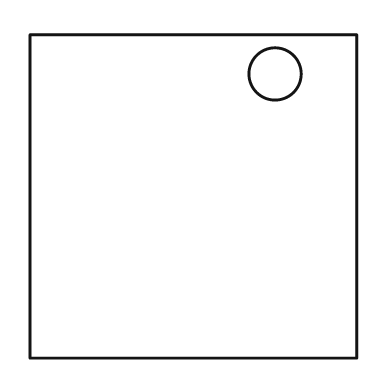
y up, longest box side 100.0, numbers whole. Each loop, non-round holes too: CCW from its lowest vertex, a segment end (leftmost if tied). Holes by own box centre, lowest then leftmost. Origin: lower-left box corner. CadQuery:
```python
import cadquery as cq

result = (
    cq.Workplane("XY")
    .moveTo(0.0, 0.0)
    .lineTo(100.0, 0.0)
    .lineTo(100.0, 99.0)
    .lineTo(0.0, 99.0)
    .close()
    .moveTo(75.0, 87.0)
    .circle(8.0)
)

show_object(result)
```